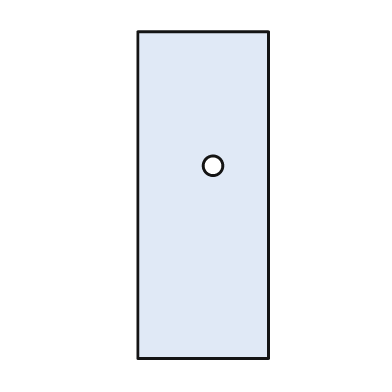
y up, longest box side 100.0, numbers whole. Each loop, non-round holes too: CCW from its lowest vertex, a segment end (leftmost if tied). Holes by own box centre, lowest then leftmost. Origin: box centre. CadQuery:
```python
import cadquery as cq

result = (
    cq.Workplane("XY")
    .moveTo(-20.0, -50.0)
    .lineTo(20.0, -50.0)
    .lineTo(20.0, 50.0)
    .lineTo(-20.0, 50.0)
    .close()
    .moveTo(3.0, 9.0)
    .circle(3.0)
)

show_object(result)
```